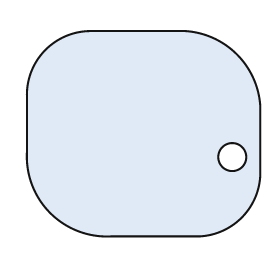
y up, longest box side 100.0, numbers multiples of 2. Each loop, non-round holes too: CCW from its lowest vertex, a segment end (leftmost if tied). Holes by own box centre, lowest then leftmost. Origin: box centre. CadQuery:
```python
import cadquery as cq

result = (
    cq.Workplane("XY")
    .moveTo(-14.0, -44.0)
    .lineTo(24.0, -44.0)
    .threePointArc((42.0, -36.0), (50.0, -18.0))
    .lineTo(50.0, 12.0)
    .threePointArc((40.0, 34.0), (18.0, 44.0))
    .lineTo(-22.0, 44.0)
    .threePointArc((-42.0, 36.0), (-50.0, 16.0))
    .lineTo(-50.0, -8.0)
    .threePointArc((-40.0, -34.0), (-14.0, -44.0))
    .close()
    .moveTo(38.0, -10.0)
    .circle(6.0)
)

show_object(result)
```